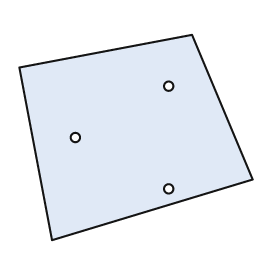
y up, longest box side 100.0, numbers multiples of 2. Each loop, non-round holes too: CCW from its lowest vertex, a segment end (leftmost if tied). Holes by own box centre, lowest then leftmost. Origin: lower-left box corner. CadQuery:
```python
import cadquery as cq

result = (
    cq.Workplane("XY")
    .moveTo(14.0, 0.0)
    .lineTo(100.0, 26.0)
    .lineTo(74.0, 88.0)
    .lineTo(0.0, 74.0)
    .close()
    .moveTo(64.0, 22.0)
    .circle(2.0)
    .moveTo(24.0, 44.0)
    .circle(2.0)
    .moveTo(64.0, 66.0)
    .circle(2.0)
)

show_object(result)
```